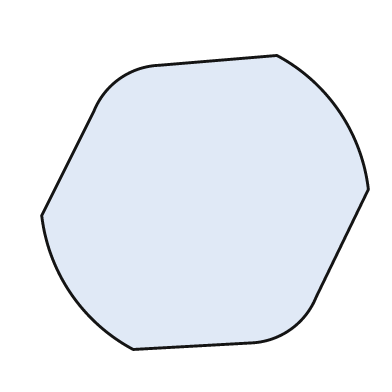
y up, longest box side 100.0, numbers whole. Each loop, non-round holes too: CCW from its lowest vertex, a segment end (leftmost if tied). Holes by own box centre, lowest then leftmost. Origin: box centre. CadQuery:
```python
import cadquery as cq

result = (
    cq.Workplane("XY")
    .moveTo(-22.0, -45.0)
    .lineTo(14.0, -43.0)
    .threePointArc((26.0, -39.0), (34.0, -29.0))
    .lineTo(50.0, 4.0)
    .threePointArc((41.0, 28.0), (22.0, 45.0))
    .lineTo(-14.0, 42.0)
    .threePointArc((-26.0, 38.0), (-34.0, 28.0))
    .lineTo(-50.0, -4.0)
    .threePointArc((-41.0, -28.0), (-22.0, -45.0))
    .close()
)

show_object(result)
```